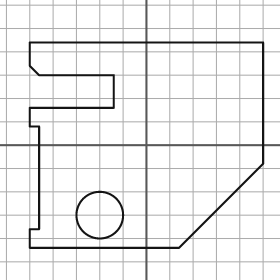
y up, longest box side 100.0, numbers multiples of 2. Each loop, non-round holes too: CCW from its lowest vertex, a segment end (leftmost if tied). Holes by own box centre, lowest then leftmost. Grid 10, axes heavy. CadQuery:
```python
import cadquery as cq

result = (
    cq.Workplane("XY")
    .moveTo(-50.0, -44.0)
    .lineTo(14.0, -44.0)
    .lineTo(50.0, -8.0)
    .lineTo(50.0, 44.0)
    .lineTo(-50.0, 44.0)
    .lineTo(-50.0, 34.0)
    .lineTo(-46.0, 30.0)
    .lineTo(-14.0, 30.0)
    .lineTo(-14.0, 16.0)
    .lineTo(-50.0, 16.0)
    .lineTo(-50.0, 8.0)
    .lineTo(-46.0, 8.0)
    .lineTo(-46.0, -36.0)
    .lineTo(-50.0, -36.0)
    .close()
    .moveTo(-20.0, -30.0)
    .circle(10.0)
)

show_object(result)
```